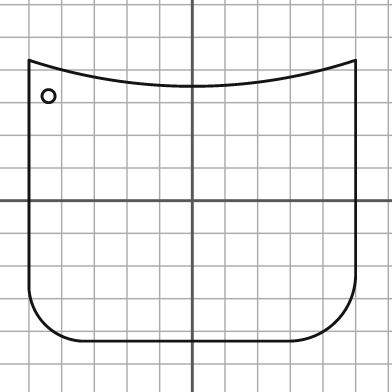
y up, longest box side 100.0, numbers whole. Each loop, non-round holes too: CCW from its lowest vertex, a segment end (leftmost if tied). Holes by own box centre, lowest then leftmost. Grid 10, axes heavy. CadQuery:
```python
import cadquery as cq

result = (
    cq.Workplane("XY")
    .moveTo(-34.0, -43.0)
    .lineTo(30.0, -43.0)
    .threePointArc((44.0, -37.0), (50.0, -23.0))
    .lineTo(50.0, 43.0)
    .threePointArc((0.0, 35.0), (-50.0, 43.0))
    .lineTo(-50.0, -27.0)
    .threePointArc((-45.0, -38.0), (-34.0, -43.0))
    .close()
    .moveTo(-44.0, 32.0)
    .circle(2.0)
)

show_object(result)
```